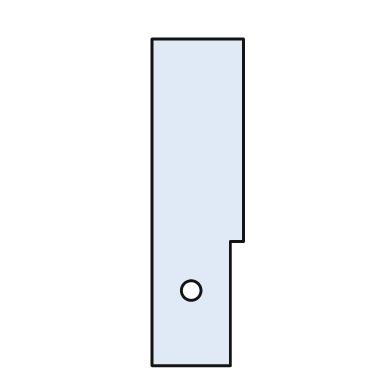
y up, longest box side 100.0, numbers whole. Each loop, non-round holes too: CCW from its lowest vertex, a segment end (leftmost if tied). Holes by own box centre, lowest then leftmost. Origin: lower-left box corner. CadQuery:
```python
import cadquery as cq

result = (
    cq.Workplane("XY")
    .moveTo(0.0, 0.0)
    .lineTo(24.0, 0.0)
    .lineTo(24.0, 38.0)
    .lineTo(28.0, 38.0)
    .lineTo(28.0, 100.0)
    .lineTo(0.0, 100.0)
    .close()
    .moveTo(12.0, 23.0)
    .circle(3.0)
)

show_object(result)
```